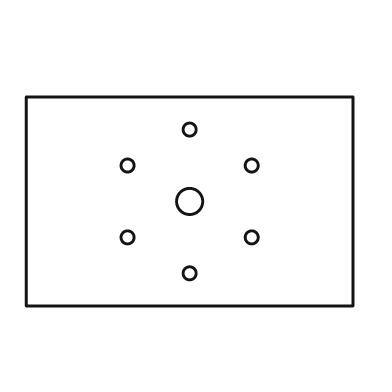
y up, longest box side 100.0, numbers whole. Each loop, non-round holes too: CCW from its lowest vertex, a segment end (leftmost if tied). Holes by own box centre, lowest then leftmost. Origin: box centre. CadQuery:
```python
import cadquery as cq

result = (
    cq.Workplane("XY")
    .moveTo(-50.0, -32.0)
    .lineTo(50.0, -32.0)
    .lineTo(50.0, 32.0)
    .lineTo(-50.0, 32.0)
    .close()
    .moveTo(0.0, -22.0)
    .circle(2.0)
    .moveTo(-19.0, -11.0)
    .circle(2.0)
    .moveTo(19.0, -11.0)
    .circle(2.0)
    .moveTo(0.0, 0.0)
    .circle(4.0)
    .moveTo(-19.0, 11.0)
    .circle(2.0)
    .moveTo(19.0, 11.0)
    .circle(2.0)
    .moveTo(0.0, 22.0)
    .circle(2.0)
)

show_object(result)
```